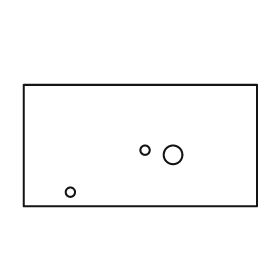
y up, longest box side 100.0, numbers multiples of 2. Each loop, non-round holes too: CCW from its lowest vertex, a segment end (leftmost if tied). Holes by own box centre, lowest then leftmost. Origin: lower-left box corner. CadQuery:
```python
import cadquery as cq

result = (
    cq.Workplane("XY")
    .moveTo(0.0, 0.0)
    .lineTo(100.0, 0.0)
    .lineTo(100.0, 52.0)
    .lineTo(0.0, 52.0)
    .close()
    .moveTo(20.0, 6.0)
    .circle(2.0)
    .moveTo(64.0, 22.0)
    .circle(4.0)
    .moveTo(52.0, 24.0)
    .circle(2.0)
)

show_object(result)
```